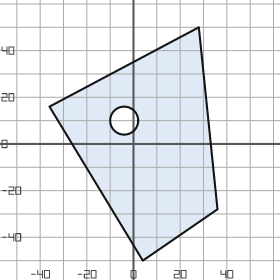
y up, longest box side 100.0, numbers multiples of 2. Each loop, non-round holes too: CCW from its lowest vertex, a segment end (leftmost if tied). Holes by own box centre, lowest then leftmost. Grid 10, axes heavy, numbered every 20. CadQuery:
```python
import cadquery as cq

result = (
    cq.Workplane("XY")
    .moveTo(4.0, -50.0)
    .lineTo(36.0, -28.0)
    .lineTo(28.0, 50.0)
    .lineTo(-36.0, 16.0)
    .close()
    .moveTo(-4.0, 10.0)
    .circle(6.0)
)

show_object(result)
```